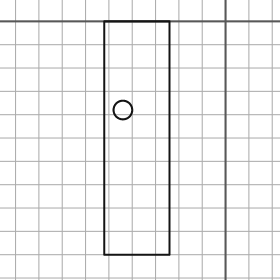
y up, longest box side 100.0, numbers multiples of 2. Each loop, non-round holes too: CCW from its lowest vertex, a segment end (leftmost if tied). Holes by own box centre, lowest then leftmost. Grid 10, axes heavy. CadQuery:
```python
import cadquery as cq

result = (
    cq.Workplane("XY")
    .moveTo(-52.0, -100.0)
    .lineTo(-24.0, -100.0)
    .lineTo(-24.0, 0.0)
    .lineTo(-52.0, 0.0)
    .close()
    .moveTo(-44.0, -38.0)
    .circle(4.0)
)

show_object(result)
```